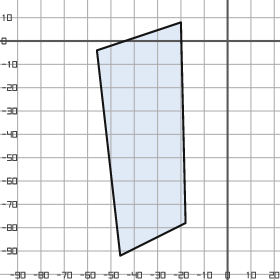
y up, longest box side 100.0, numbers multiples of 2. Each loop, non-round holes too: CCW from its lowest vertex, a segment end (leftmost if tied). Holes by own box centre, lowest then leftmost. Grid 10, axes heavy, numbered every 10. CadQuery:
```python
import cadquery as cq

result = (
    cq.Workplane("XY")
    .moveTo(-46.0, -92.0)
    .lineTo(-18.0, -78.0)
    .lineTo(-20.0, 8.0)
    .lineTo(-56.0, -4.0)
    .close()
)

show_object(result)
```